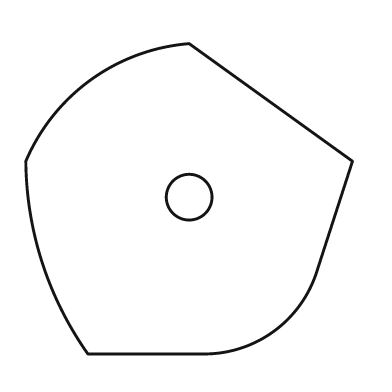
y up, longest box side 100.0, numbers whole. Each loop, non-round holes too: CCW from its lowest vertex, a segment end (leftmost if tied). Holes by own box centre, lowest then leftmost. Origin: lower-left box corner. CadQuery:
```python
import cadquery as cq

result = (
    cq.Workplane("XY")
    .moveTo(19.0, 0.0)
    .lineTo(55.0, 0.0)
    .threePointArc((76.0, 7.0), (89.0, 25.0))
    .lineTo(100.0, 59.0)
    .lineTo(50.0, 95.0)
    .threePointArc((20.0, 84.0), (0.0, 59.0))
    .threePointArc((5.0, 28.0), (19.0, 0.0))
    .close()
    .moveTo(50.0, 48.0)
    .circle(7.0)
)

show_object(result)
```